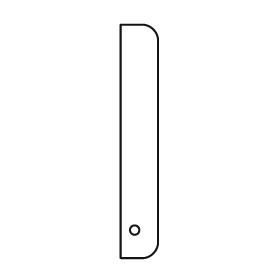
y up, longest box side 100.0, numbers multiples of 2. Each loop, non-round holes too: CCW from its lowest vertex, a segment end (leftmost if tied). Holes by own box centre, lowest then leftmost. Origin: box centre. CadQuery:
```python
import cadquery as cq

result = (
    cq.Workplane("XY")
    .moveTo(-8.0, -50.0)
    .lineTo(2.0, -50.0)
    .threePointArc((6.0, -48.0), (8.0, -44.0))
    .lineTo(8.0, 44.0)
    .threePointArc((6.0, 48.0), (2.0, 50.0))
    .lineTo(-8.0, 50.0)
    .close()
    .moveTo(-2.0, -38.0)
    .circle(2.0)
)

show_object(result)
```